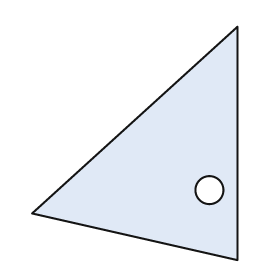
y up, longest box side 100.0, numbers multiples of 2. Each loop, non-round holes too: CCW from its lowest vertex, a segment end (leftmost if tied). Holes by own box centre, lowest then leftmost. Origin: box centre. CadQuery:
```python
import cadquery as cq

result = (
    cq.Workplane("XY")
    .moveTo(44.0, -50.0)
    .lineTo(44.0, 50.0)
    .lineTo(-44.0, -30.0)
    .close()
    .moveTo(32.0, -20.0)
    .circle(6.0)
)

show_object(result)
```